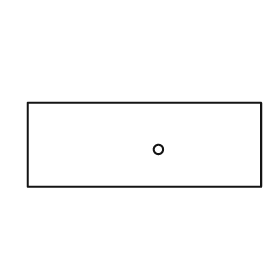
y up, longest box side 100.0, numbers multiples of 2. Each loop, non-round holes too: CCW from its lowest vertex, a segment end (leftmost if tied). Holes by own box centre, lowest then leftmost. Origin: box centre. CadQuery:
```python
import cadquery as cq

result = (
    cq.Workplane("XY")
    .moveTo(-50.0, -18.0)
    .lineTo(50.0, -18.0)
    .lineTo(50.0, 18.0)
    .lineTo(-50.0, 18.0)
    .close()
    .moveTo(6.0, -2.0)
    .circle(2.0)
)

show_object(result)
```